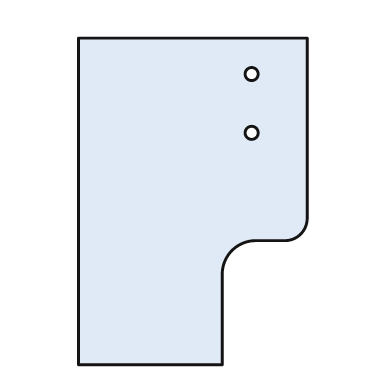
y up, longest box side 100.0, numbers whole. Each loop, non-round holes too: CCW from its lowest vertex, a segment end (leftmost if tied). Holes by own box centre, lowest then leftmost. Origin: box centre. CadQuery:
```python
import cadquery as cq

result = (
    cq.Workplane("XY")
    .moveTo(-35.0, -50.0)
    .lineTo(9.0, -50.0)
    .lineTo(9.0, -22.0)
    .threePointArc((12.0, -15.0), (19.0, -12.0))
    .lineTo(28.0, -12.0)
    .threePointArc((33.0, -10.0), (35.0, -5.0))
    .lineTo(35.0, 50.0)
    .lineTo(-35.0, 50.0)
    .close()
    .moveTo(18.0, 21.0)
    .circle(2.0)
    .moveTo(18.0, 39.0)
    .circle(2.0)
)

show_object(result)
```